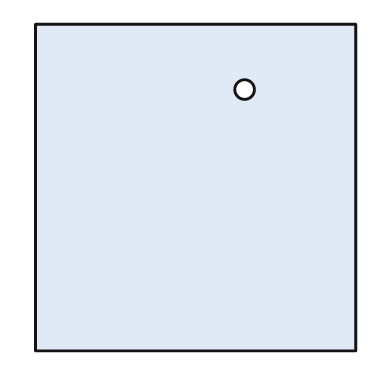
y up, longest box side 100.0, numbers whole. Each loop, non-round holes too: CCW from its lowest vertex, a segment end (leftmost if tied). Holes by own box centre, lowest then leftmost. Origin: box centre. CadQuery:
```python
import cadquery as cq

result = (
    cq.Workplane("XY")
    .moveTo(-49.0, -50.0)
    .lineTo(49.0, -50.0)
    .lineTo(49.0, 50.0)
    .lineTo(-49.0, 50.0)
    .close()
    .moveTo(15.0, 30.0)
    .circle(3.0)
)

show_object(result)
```